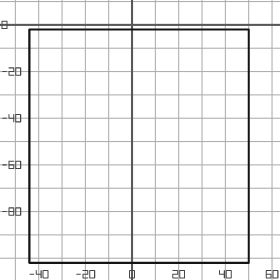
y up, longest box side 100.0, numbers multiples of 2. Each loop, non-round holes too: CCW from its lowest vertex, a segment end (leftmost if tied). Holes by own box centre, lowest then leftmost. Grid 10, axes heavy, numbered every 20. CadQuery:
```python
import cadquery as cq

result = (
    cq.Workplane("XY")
    .moveTo(-44.0, -102.0)
    .lineTo(50.0, -102.0)
    .lineTo(50.0, -2.0)
    .lineTo(-44.0, -2.0)
    .close()
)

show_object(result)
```